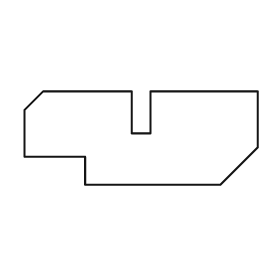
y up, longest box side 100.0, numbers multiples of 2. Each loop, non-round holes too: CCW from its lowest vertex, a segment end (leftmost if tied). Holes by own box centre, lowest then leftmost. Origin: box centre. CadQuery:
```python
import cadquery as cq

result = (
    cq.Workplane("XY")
    .moveTo(-24.0, -20.0)
    .lineTo(34.0, -20.0)
    .lineTo(50.0, -4.0)
    .lineTo(50.0, 20.0)
    .lineTo(4.0, 20.0)
    .lineTo(4.0, 2.0)
    .lineTo(-4.0, 2.0)
    .lineTo(-4.0, 20.0)
    .lineTo(-42.0, 20.0)
    .lineTo(-50.0, 12.0)
    .lineTo(-50.0, -8.0)
    .lineTo(-24.0, -8.0)
    .close()
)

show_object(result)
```